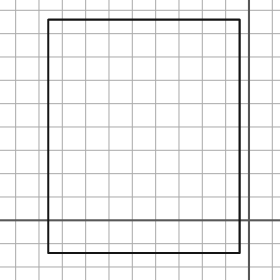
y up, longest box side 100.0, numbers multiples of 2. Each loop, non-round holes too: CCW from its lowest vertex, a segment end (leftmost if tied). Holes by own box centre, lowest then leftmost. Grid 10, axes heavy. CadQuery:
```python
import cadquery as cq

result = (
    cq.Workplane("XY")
    .moveTo(-86.0, -14.0)
    .lineTo(-4.0, -14.0)
    .lineTo(-4.0, 86.0)
    .lineTo(-86.0, 86.0)
    .close()
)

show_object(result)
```